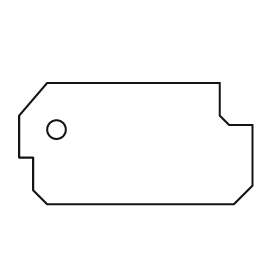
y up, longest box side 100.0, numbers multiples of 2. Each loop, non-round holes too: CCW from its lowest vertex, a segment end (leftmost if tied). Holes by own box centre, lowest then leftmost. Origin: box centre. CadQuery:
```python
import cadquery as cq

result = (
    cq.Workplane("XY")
    .moveTo(-38.0, -26.0)
    .lineTo(42.0, -26.0)
    .lineTo(50.0, -18.0)
    .lineTo(50.0, 8.0)
    .lineTo(40.0, 8.0)
    .lineTo(36.0, 12.0)
    .lineTo(36.0, 26.0)
    .lineTo(-38.0, 26.0)
    .lineTo(-50.0, 12.0)
    .lineTo(-50.0, -6.0)
    .lineTo(-44.0, -6.0)
    .lineTo(-44.0, -20.0)
    .close()
    .moveTo(-34.0, 6.0)
    .circle(4.0)
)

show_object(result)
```